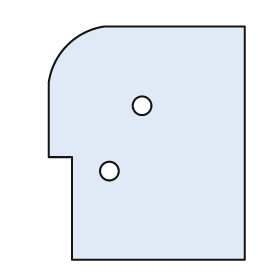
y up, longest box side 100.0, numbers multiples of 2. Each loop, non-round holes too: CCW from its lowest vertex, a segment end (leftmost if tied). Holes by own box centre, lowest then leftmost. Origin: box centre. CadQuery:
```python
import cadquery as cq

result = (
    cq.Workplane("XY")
    .moveTo(-32.0, -50.0)
    .lineTo(42.0, -50.0)
    .lineTo(42.0, 50.0)
    .lineTo(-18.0, 50.0)
    .threePointArc((-34.0, 42.0), (-42.0, 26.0))
    .lineTo(-42.0, -6.0)
    .lineTo(-32.0, -6.0)
    .close()
    .moveTo(-16.0, -12.0)
    .circle(4.0)
    .moveTo(-2.0, 16.0)
    .circle(4.0)
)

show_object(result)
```